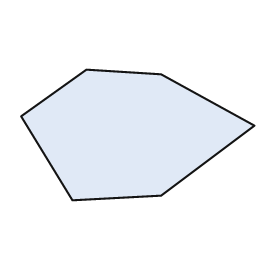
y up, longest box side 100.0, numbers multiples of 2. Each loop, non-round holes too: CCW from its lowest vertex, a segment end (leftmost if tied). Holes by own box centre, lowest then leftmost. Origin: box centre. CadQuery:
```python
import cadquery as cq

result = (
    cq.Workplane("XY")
    .moveTo(-28.0, -28.0)
    .lineTo(10.0, -26.0)
    .lineTo(50.0, 4.0)
    .lineTo(10.0, 26.0)
    .lineTo(-22.0, 28.0)
    .lineTo(-50.0, 8.0)
    .close()
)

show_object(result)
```